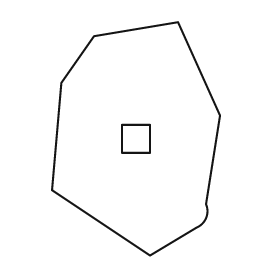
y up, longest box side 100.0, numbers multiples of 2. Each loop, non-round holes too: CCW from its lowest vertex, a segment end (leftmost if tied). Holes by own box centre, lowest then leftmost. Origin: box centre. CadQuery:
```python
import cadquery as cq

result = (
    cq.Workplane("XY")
    .moveTo(6.0, -50.0)
    .lineTo(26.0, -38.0)
    .threePointArc((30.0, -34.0), (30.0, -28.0))
    .lineTo(36.0, 10.0)
    .lineTo(18.0, 50.0)
    .lineTo(-18.0, 44.0)
    .lineTo(-32.0, 24.0)
    .lineTo(-36.0, -22.0)
    .close()
    .moveTo(-6.0, -6.0)
    .lineTo(6.0, -6.0)
    .lineTo(6.0, 6.0)
    .lineTo(-6.0, 6.0)
    .close()
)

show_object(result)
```